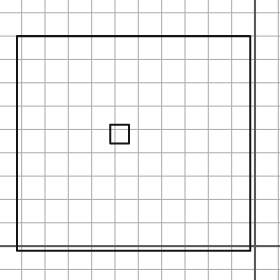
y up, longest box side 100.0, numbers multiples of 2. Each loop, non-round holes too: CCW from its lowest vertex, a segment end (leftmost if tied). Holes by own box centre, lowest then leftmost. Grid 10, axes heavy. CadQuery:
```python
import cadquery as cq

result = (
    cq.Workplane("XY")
    .moveTo(-102.0, -2.0)
    .lineTo(-2.0, -2.0)
    .lineTo(-2.0, 90.0)
    .lineTo(-102.0, 90.0)
    .close()
    .moveTo(-62.0, 44.0)
    .lineTo(-54.0, 44.0)
    .lineTo(-54.0, 52.0)
    .lineTo(-62.0, 52.0)
    .close()
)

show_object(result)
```